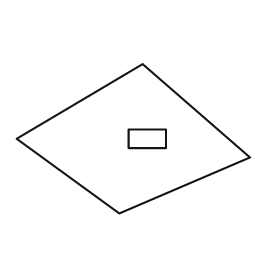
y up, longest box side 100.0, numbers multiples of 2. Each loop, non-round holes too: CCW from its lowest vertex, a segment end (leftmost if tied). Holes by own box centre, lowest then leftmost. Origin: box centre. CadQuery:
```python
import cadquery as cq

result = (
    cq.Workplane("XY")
    .moveTo(-6.0, -32.0)
    .lineTo(50.0, -8.0)
    .lineTo(4.0, 32.0)
    .lineTo(-50.0, 0.0)
    .close()
    .moveTo(-2.0, -4.0)
    .lineTo(14.0, -4.0)
    .lineTo(14.0, 4.0)
    .lineTo(-2.0, 4.0)
    .close()
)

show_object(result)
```